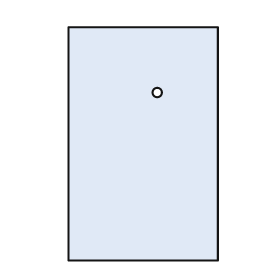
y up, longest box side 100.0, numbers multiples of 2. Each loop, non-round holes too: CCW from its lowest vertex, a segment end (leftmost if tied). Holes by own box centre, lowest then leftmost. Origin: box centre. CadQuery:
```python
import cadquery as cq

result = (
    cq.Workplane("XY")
    .moveTo(-32.0, -50.0)
    .lineTo(32.0, -50.0)
    .lineTo(32.0, 50.0)
    .lineTo(-32.0, 50.0)
    .close()
    .moveTo(6.0, 22.0)
    .circle(2.0)
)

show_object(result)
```